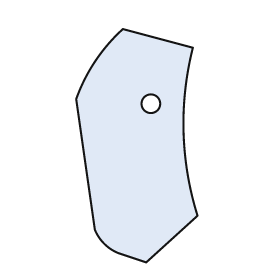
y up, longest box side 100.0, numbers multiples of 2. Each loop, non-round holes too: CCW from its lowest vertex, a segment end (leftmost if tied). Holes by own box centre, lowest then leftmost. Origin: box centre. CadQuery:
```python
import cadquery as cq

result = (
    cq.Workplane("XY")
    .moveTo(4.0, -50.0)
    .lineTo(26.0, -30.0)
    .threePointArc((20.0, 6.0), (24.0, 42.0))
    .lineTo(-6.0, 50.0)
    .threePointArc((-18.0, 36.0), (-26.0, 20.0))
    .lineTo(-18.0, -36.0)
    .threePointArc((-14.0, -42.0), (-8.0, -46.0))
    .close()
    .moveTo(6.0, 18.0)
    .circle(4.0)
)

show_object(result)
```